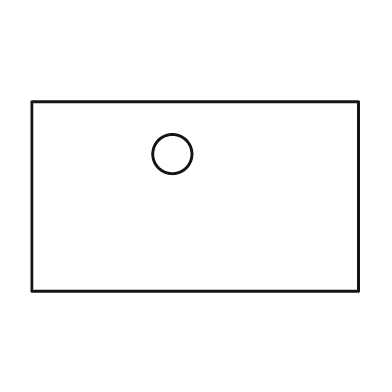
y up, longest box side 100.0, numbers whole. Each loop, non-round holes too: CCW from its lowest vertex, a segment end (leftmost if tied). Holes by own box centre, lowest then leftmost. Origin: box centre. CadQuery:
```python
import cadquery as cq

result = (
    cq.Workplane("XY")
    .moveTo(-50.0, -29.0)
    .lineTo(50.0, -29.0)
    .lineTo(50.0, 29.0)
    .lineTo(-50.0, 29.0)
    .close()
    .moveTo(-7.0, 13.0)
    .circle(6.0)
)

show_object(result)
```